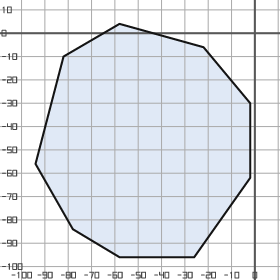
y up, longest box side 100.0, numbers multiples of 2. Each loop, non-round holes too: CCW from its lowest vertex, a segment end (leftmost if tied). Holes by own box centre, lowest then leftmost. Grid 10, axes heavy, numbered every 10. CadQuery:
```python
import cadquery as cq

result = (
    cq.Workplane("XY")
    .moveTo(-58.0, -96.0)
    .lineTo(-26.0, -96.0)
    .lineTo(-2.0, -62.0)
    .lineTo(-2.0, -30.0)
    .lineTo(-22.0, -6.0)
    .lineTo(-58.0, 4.0)
    .lineTo(-82.0, -10.0)
    .lineTo(-94.0, -56.0)
    .lineTo(-78.0, -84.0)
    .close()
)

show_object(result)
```